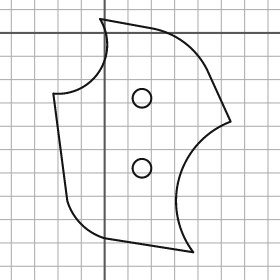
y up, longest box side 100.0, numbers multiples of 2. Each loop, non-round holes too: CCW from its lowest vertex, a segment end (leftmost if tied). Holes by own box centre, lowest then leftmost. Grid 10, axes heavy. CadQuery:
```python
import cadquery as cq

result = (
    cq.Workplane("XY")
    .moveTo(38.0, -94.0)
    .threePointArc((32.0, -62.0), (54.0, -38.0))
    .lineTo(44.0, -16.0)
    .threePointArc((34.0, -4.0), (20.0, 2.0))
    .lineTo(-2.0, 6.0)
    .threePointArc((-2.0, -16.0), (-22.0, -26.0))
    .lineTo(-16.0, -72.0)
    .threePointArc((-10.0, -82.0), (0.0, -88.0))
    .close()
    .moveTo(16.0, -58.0)
    .circle(4.0)
    .moveTo(16.0, -28.0)
    .circle(4.0)
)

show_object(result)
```